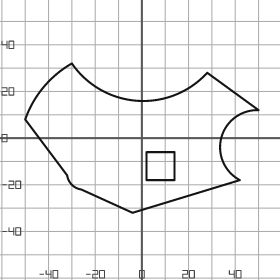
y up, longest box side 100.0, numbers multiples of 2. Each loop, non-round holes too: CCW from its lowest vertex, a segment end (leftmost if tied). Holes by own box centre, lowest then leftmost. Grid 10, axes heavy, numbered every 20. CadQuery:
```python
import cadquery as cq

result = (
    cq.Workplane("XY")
    .moveTo(-4.0, -32.0)
    .lineTo(42.0, -18.0)
    .threePointArc((34.0, 0.0), (50.0, 12.0))
    .lineTo(28.0, 28.0)
    .threePointArc((-2.0, 16.0), (-30.0, 32.0))
    .threePointArc((-42.0, 22.0), (-50.0, 8.0))
    .lineTo(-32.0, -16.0)
    .threePointArc((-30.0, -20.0), (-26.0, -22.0))
    .close()
    .moveTo(2.0, -18.0)
    .lineTo(14.0, -18.0)
    .lineTo(14.0, -6.0)
    .lineTo(2.0, -6.0)
    .close()
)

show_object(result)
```